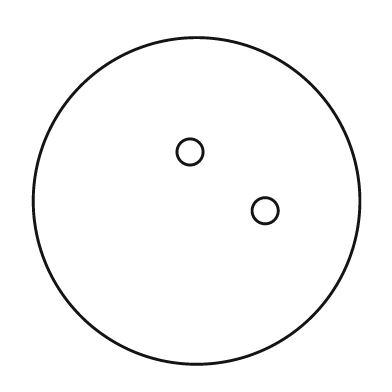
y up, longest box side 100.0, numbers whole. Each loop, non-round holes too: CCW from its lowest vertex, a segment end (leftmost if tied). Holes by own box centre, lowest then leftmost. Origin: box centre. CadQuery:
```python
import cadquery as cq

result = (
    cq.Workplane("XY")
    .moveTo(0.0, 0.0)
    .circle(50.0)
    .moveTo(21.0, -3.0)
    .circle(4.0)
    .moveTo(-2.0, 15.0)
    .circle(4.0)
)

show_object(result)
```